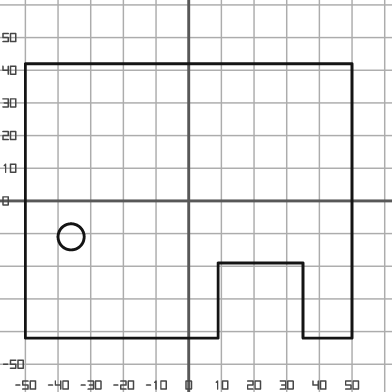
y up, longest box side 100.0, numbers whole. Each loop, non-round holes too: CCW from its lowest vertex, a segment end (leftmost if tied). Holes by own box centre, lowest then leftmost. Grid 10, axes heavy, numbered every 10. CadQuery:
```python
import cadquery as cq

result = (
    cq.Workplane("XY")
    .moveTo(-50.0, -42.0)
    .lineTo(9.0, -42.0)
    .lineTo(9.0, -19.0)
    .lineTo(35.0, -19.0)
    .lineTo(35.0, -42.0)
    .lineTo(50.0, -42.0)
    .lineTo(50.0, 42.0)
    .lineTo(-50.0, 42.0)
    .close()
    .moveTo(-36.0, -11.0)
    .circle(4.0)
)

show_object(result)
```